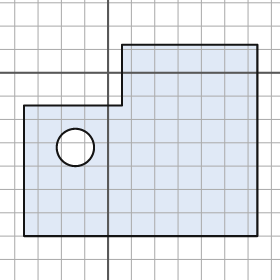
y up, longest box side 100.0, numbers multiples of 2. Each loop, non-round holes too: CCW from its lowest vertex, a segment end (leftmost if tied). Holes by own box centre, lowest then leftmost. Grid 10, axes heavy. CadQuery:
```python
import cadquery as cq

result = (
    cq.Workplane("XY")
    .moveTo(-36.0, -70.0)
    .lineTo(64.0, -70.0)
    .lineTo(64.0, 12.0)
    .lineTo(6.0, 12.0)
    .lineTo(6.0, -14.0)
    .lineTo(-36.0, -14.0)
    .close()
    .moveTo(-14.0, -32.0)
    .circle(8.0)
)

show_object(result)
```